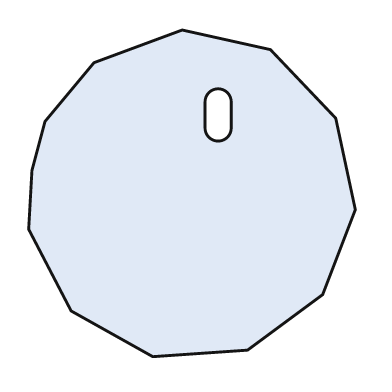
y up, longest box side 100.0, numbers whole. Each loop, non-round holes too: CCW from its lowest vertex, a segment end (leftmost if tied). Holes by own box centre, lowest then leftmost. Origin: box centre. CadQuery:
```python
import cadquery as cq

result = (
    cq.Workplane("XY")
    .moveTo(-12.0, -50.0)
    .lineTo(17.0, -48.0)
    .lineTo(40.0, -31.0)
    .lineTo(50.0, -5.0)
    .lineTo(44.0, 23.0)
    .lineTo(24.0, 44.0)
    .lineTo(-3.0, 50.0)
    .lineTo(-30.0, 40.0)
    .lineTo(-45.0, 22.0)
    .lineTo(-49.0, 7.0)
    .lineTo(-50.0, -11.0)
    .lineTo(-37.0, -36.0)
    .close()
    .moveTo(4.0, 20.0)
    .threePointArc((8.0, 16.0), (12.0, 20.0))
    .lineTo(12.0, 28.0)
    .threePointArc((8.0, 32.0), (4.0, 28.0))
    .close()
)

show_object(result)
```